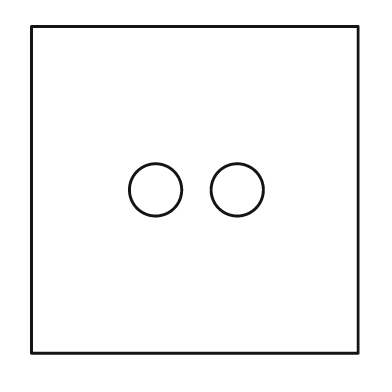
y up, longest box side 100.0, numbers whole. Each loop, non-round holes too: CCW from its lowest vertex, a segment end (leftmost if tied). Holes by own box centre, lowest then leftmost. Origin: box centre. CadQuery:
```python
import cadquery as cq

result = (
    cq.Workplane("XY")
    .moveTo(-50.0, -50.0)
    .lineTo(50.0, -50.0)
    .lineTo(50.0, 50.0)
    .lineTo(-50.0, 50.0)
    .close()
    .moveTo(-12.0, 0.0)
    .circle(8.0)
    .moveTo(13.0, 0.0)
    .circle(8.0)
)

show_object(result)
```